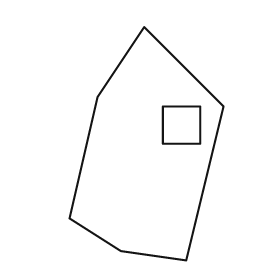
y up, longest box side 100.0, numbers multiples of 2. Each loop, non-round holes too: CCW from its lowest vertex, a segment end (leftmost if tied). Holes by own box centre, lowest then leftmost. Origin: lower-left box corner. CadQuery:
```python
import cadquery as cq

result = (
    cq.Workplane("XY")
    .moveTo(50.0, 0.0)
    .lineTo(66.0, 66.0)
    .lineTo(32.0, 100.0)
    .lineTo(12.0, 70.0)
    .lineTo(0.0, 18.0)
    .lineTo(22.0, 4.0)
    .close()
    .moveTo(40.0, 50.0)
    .lineTo(56.0, 50.0)
    .lineTo(56.0, 66.0)
    .lineTo(40.0, 66.0)
    .close()
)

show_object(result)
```